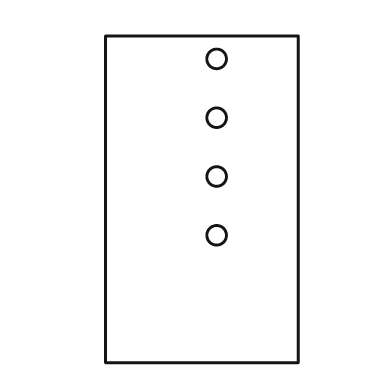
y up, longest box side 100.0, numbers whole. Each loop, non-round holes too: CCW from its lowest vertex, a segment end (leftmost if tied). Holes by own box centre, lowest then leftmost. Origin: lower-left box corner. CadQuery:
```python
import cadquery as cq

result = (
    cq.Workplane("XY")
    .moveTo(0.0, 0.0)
    .lineTo(59.0, 0.0)
    .lineTo(59.0, 100.0)
    .lineTo(0.0, 100.0)
    .close()
    .moveTo(34.0, 39.0)
    .circle(3.0)
    .moveTo(34.0, 57.0)
    .circle(3.0)
    .moveTo(34.0, 75.0)
    .circle(3.0)
    .moveTo(34.0, 93.0)
    .circle(3.0)
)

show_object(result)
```